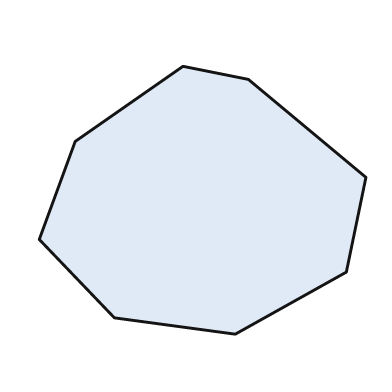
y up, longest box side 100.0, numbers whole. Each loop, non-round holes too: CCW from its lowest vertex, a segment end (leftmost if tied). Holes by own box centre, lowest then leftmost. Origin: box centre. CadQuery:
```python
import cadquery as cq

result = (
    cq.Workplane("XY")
    .moveTo(10.0, -41.0)
    .lineTo(44.0, -22.0)
    .lineTo(50.0, 7.0)
    .lineTo(14.0, 37.0)
    .lineTo(-6.0, 41.0)
    .lineTo(-39.0, 18.0)
    .lineTo(-50.0, -12.0)
    .lineTo(-27.0, -36.0)
    .close()
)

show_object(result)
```